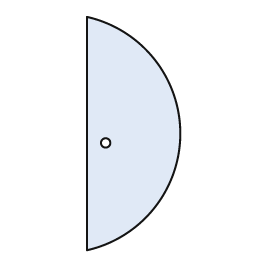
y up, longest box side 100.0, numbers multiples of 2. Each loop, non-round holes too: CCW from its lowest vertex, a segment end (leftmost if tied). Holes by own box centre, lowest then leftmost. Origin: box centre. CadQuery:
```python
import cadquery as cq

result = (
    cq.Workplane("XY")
    .moveTo(-20.0, -50.0)
    .threePointArc((20.0, 0.0), (-20.0, 50.0))
    .close()
    .moveTo(-12.0, -4.0)
    .circle(2.0)
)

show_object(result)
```